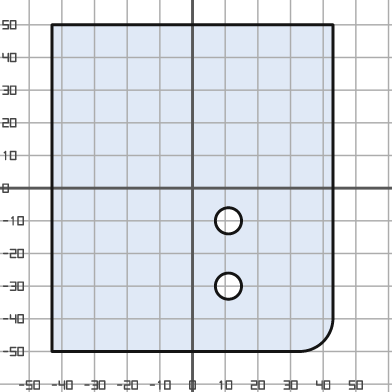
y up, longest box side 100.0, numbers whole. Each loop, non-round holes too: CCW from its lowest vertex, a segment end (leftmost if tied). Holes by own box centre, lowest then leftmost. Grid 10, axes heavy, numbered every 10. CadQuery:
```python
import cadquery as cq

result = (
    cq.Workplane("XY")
    .moveTo(-43.0, -50.0)
    .lineTo(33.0, -50.0)
    .threePointArc((40.0, -47.0), (43.0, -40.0))
    .lineTo(43.0, 50.0)
    .lineTo(-43.0, 50.0)
    .close()
    .moveTo(11.0, -30.0)
    .circle(4.0)
    .moveTo(11.0, -10.0)
    .circle(4.0)
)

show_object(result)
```